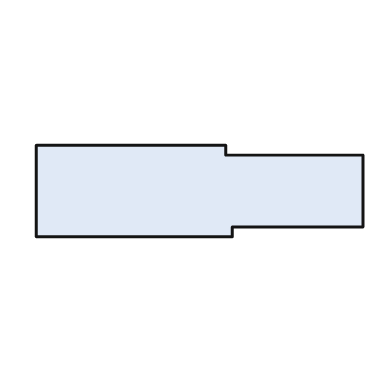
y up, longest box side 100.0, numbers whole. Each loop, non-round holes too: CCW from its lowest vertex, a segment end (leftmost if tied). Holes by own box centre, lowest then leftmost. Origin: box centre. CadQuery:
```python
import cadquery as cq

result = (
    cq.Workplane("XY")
    .moveTo(-50.0, -14.0)
    .lineTo(10.0, -14.0)
    .lineTo(10.0, -11.0)
    .lineTo(50.0, -11.0)
    .lineTo(50.0, 11.0)
    .lineTo(8.0, 11.0)
    .lineTo(8.0, 14.0)
    .lineTo(-50.0, 14.0)
    .close()
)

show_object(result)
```